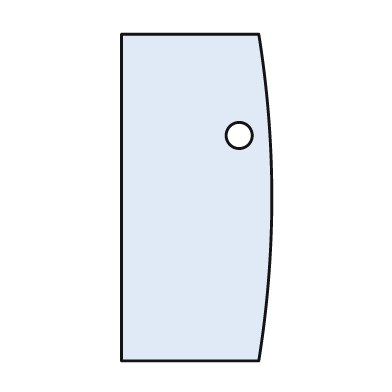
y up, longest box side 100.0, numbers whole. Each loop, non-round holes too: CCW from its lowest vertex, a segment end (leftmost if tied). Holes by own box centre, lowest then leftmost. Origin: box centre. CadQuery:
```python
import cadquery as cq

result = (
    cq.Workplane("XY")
    .moveTo(-23.0, -50.0)
    .lineTo(19.0, -50.0)
    .threePointArc((23.0, 0.0), (19.0, 50.0))
    .lineTo(-23.0, 50.0)
    .close()
    .moveTo(13.0, 19.0)
    .circle(4.0)
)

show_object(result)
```